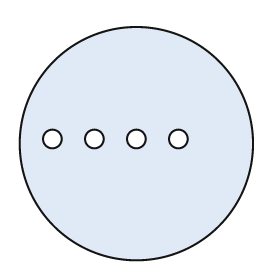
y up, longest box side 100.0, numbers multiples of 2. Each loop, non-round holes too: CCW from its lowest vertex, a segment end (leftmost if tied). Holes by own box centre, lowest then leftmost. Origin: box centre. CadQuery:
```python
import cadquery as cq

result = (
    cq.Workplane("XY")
    .moveTo(0.0, 0.0)
    .circle(50.0)
    .moveTo(-36.0, 2.0)
    .circle(4.0)
    .moveTo(-18.0, 2.0)
    .circle(4.0)
    .moveTo(0.0, 2.0)
    .circle(4.0)
    .moveTo(18.0, 2.0)
    .circle(4.0)
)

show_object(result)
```